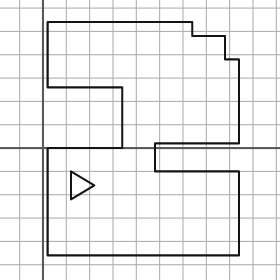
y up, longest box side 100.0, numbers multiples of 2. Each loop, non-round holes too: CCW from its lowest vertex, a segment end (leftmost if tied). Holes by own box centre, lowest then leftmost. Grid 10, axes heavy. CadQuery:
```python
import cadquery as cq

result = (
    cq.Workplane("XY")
    .moveTo(2.0, -46.0)
    .lineTo(84.0, -46.0)
    .lineTo(84.0, -10.0)
    .lineTo(48.0, -10.0)
    .lineTo(48.0, 2.0)
    .lineTo(84.0, 2.0)
    .lineTo(84.0, 38.0)
    .lineTo(78.0, 38.0)
    .lineTo(78.0, 48.0)
    .lineTo(64.0, 48.0)
    .lineTo(64.0, 54.0)
    .lineTo(2.0, 54.0)
    .lineTo(2.0, 26.0)
    .lineTo(34.0, 26.0)
    .lineTo(34.0, 0.0)
    .lineTo(2.0, 0.0)
    .close()
    .moveTo(12.0, -22.0)
    .lineTo(22.0, -16.0)
    .lineTo(12.0, -10.0)
    .close()
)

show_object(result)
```